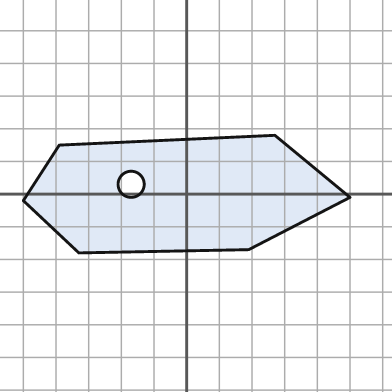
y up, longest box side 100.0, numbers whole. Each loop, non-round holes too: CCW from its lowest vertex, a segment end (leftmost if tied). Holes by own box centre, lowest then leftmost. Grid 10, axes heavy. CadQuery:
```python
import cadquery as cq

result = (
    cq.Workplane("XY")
    .moveTo(-33.0, -18.0)
    .lineTo(19.0, -17.0)
    .lineTo(50.0, -1.0)
    .lineTo(27.0, 18.0)
    .lineTo(-39.0, 15.0)
    .lineTo(-50.0, -2.0)
    .close()
    .moveTo(-17.0, 3.0)
    .circle(4.0)
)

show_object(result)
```